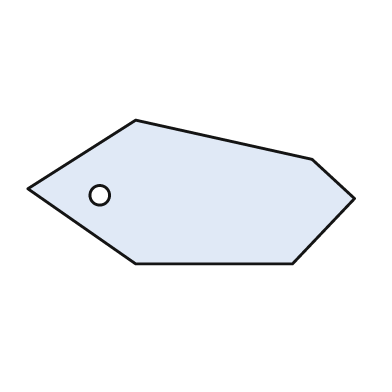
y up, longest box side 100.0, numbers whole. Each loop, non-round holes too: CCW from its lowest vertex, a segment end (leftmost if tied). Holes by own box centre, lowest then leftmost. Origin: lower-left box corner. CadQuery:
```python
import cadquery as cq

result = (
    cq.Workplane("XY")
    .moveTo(33.0, 0.0)
    .lineTo(81.0, 0.0)
    .lineTo(100.0, 20.0)
    .lineTo(87.0, 32.0)
    .lineTo(33.0, 44.0)
    .lineTo(0.0, 23.0)
    .close()
    .moveTo(22.0, 21.0)
    .circle(3.0)
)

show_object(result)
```